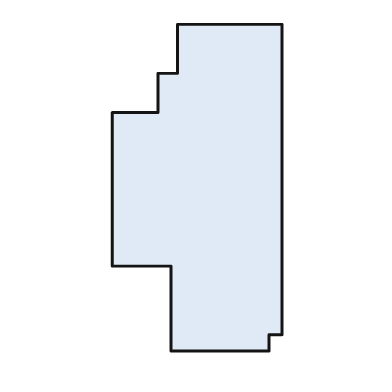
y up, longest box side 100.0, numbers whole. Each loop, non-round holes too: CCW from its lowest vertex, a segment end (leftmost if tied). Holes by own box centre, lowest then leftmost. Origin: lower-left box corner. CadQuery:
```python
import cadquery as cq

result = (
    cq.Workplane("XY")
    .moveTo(18.0, 0.0)
    .lineTo(48.0, 0.0)
    .lineTo(48.0, 5.0)
    .lineTo(52.0, 5.0)
    .lineTo(52.0, 100.0)
    .lineTo(20.0, 100.0)
    .lineTo(20.0, 85.0)
    .lineTo(14.0, 85.0)
    .lineTo(14.0, 73.0)
    .lineTo(0.0, 73.0)
    .lineTo(0.0, 26.0)
    .lineTo(18.0, 26.0)
    .close()
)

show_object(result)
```